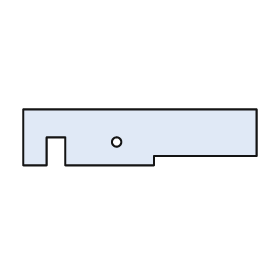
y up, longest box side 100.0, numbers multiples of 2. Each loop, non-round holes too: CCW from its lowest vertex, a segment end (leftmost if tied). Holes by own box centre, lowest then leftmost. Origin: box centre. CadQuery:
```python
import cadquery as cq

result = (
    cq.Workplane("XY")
    .moveTo(-50.0, -12.0)
    .lineTo(-40.0, -12.0)
    .lineTo(-40.0, 0.0)
    .lineTo(-32.0, 0.0)
    .lineTo(-32.0, -12.0)
    .lineTo(6.0, -12.0)
    .lineTo(6.0, -8.0)
    .lineTo(50.0, -8.0)
    .lineTo(50.0, 12.0)
    .lineTo(-50.0, 12.0)
    .close()
    .moveTo(-10.0, -2.0)
    .circle(2.0)
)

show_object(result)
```